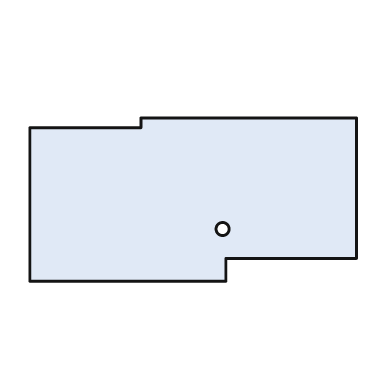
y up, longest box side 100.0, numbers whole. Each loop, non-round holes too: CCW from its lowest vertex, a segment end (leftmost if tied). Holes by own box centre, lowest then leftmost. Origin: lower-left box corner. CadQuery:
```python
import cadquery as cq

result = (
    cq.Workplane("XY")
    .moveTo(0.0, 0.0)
    .lineTo(60.0, 0.0)
    .lineTo(60.0, 7.0)
    .lineTo(100.0, 7.0)
    .lineTo(100.0, 50.0)
    .lineTo(34.0, 50.0)
    .lineTo(34.0, 47.0)
    .lineTo(0.0, 47.0)
    .close()
    .moveTo(59.0, 16.0)
    .circle(2.0)
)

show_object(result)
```